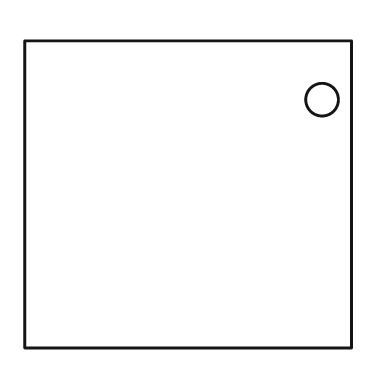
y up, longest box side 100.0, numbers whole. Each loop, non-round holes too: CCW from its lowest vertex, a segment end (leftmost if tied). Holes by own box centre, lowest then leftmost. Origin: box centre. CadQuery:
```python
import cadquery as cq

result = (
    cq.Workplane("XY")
    .moveTo(-50.0, -47.0)
    .lineTo(50.0, -47.0)
    .lineTo(50.0, 47.0)
    .lineTo(-50.0, 47.0)
    .close()
    .moveTo(41.0, 29.0)
    .circle(5.0)
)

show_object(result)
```